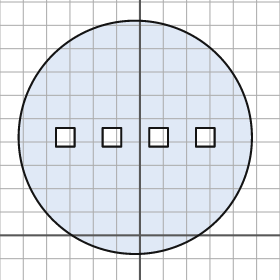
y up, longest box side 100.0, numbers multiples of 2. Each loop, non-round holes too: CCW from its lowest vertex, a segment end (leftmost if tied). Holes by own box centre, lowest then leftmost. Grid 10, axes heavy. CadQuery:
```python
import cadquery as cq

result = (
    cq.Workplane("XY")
    .moveTo(-2.0, 42.0)
    .circle(50.0)
    .moveTo(-36.0, 38.0)
    .lineTo(-28.0, 38.0)
    .lineTo(-28.0, 46.0)
    .lineTo(-36.0, 46.0)
    .close()
    .moveTo(-16.0, 38.0)
    .lineTo(-8.0, 38.0)
    .lineTo(-8.0, 46.0)
    .lineTo(-16.0, 46.0)
    .close()
    .moveTo(4.0, 38.0)
    .lineTo(12.0, 38.0)
    .lineTo(12.0, 46.0)
    .lineTo(4.0, 46.0)
    .close()
    .moveTo(24.0, 38.0)
    .lineTo(32.0, 38.0)
    .lineTo(32.0, 46.0)
    .lineTo(24.0, 46.0)
    .close()
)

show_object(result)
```